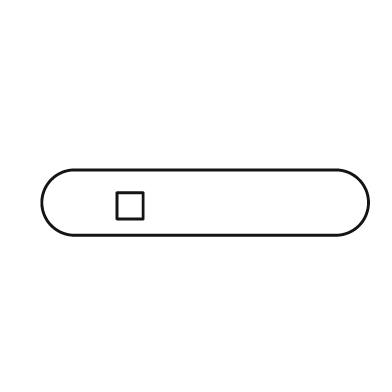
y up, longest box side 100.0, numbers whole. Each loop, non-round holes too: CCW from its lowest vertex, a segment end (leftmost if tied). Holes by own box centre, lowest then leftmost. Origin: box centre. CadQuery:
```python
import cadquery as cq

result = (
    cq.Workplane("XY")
    .moveTo(-40.0, -10.0)
    .lineTo(40.0, -10.0)
    .threePointArc((50.0, 0.0), (40.0, 10.0))
    .lineTo(-40.0, 10.0)
    .threePointArc((-50.0, 0.0), (-40.0, -10.0))
    .close()
    .moveTo(-27.0, -5.0)
    .lineTo(-19.0, -5.0)
    .lineTo(-19.0, 3.0)
    .lineTo(-27.0, 3.0)
    .close()
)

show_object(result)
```